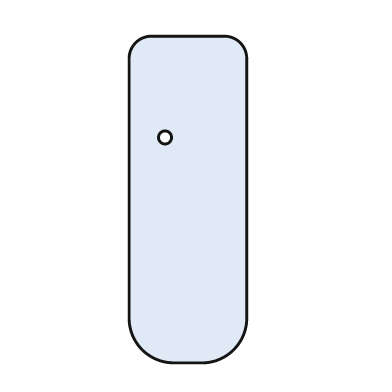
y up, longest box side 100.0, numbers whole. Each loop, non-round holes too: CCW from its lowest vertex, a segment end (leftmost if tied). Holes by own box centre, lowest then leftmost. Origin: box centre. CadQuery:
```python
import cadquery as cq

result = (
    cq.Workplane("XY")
    .moveTo(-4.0, -50.0)
    .lineTo(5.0, -50.0)
    .threePointArc((14.0, -46.0), (18.0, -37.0))
    .lineTo(18.0, 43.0)
    .threePointArc((16.0, 48.0), (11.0, 50.0))
    .lineTo(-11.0, 50.0)
    .threePointArc((-16.0, 48.0), (-18.0, 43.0))
    .lineTo(-18.0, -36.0)
    .threePointArc((-14.0, -46.0), (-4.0, -50.0))
    .close()
    .moveTo(-7.0, 19.0)
    .circle(2.0)
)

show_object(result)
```